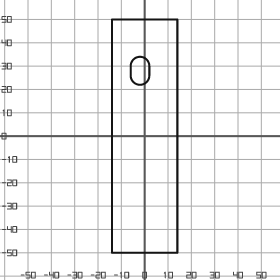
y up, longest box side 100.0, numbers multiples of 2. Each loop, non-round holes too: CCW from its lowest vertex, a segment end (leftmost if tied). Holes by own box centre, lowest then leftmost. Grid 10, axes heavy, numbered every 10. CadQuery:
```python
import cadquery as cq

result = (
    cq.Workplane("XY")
    .moveTo(-14.0, -50.0)
    .lineTo(14.0, -50.0)
    .lineTo(14.0, 50.0)
    .lineTo(-14.0, 50.0)
    .close()
    .moveTo(-6.0, 26.0)
    .threePointArc((-2.0, 22.0), (2.0, 26.0))
    .lineTo(2.0, 30.0)
    .threePointArc((-2.0, 34.0), (-6.0, 30.0))
    .close()
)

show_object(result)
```